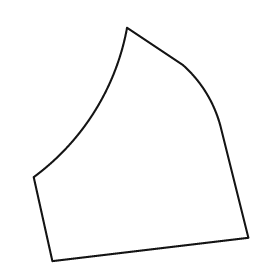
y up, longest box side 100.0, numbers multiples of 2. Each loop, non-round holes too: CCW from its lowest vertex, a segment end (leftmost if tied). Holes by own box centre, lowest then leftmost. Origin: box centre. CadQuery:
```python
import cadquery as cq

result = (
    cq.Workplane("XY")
    .moveTo(-38.0, -50.0)
    .lineTo(46.0, -40.0)
    .lineTo(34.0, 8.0)
    .threePointArc((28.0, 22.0), (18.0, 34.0))
    .lineTo(-6.0, 50.0)
    .threePointArc((-20.0, 14.0), (-46.0, -14.0))
    .close()
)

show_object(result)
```